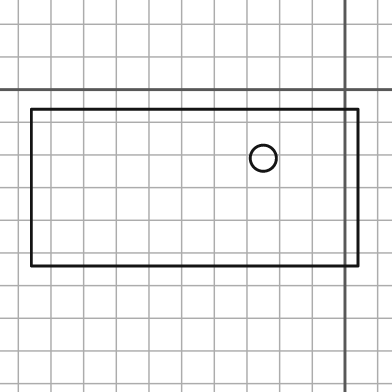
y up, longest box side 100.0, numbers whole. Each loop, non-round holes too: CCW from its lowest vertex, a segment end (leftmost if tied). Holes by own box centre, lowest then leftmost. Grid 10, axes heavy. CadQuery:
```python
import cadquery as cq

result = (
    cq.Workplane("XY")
    .moveTo(-96.0, -54.0)
    .lineTo(4.0, -54.0)
    .lineTo(4.0, -6.0)
    .lineTo(-96.0, -6.0)
    .close()
    .moveTo(-25.0, -21.0)
    .circle(4.0)
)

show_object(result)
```